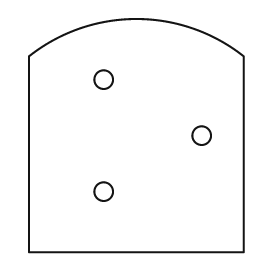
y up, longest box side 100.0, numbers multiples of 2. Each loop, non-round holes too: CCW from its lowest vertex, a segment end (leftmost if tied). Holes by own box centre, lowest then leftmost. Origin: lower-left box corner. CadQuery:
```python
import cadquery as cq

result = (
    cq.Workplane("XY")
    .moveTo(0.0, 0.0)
    .lineTo(92.0, 0.0)
    .lineTo(92.0, 84.0)
    .threePointArc((46.0, 100.0), (0.0, 84.0))
    .close()
    .moveTo(32.0, 26.0)
    .circle(4.0)
    .moveTo(74.0, 50.0)
    .circle(4.0)
    .moveTo(32.0, 74.0)
    .circle(4.0)
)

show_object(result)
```